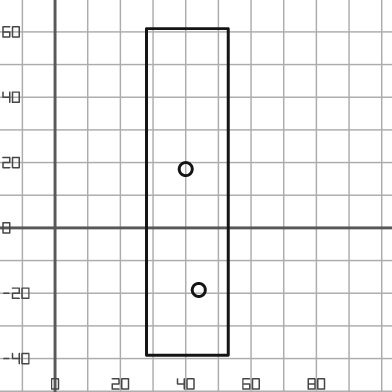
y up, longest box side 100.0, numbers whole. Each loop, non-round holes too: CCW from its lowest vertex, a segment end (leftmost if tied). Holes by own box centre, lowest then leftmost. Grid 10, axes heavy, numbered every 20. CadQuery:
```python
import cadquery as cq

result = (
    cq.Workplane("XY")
    .moveTo(28.0, -39.0)
    .lineTo(53.0, -39.0)
    .lineTo(53.0, 61.0)
    .lineTo(28.0, 61.0)
    .close()
    .moveTo(44.0, -19.0)
    .circle(2.0)
    .moveTo(40.0, 18.0)
    .circle(2.0)
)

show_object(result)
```